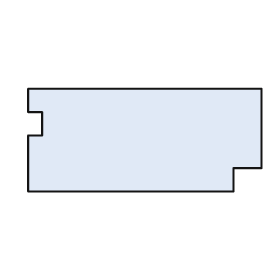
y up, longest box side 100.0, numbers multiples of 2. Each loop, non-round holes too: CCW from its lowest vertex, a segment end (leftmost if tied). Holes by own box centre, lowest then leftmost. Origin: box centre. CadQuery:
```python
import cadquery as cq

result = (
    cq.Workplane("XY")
    .moveTo(-50.0, -22.0)
    .lineTo(38.0, -22.0)
    .lineTo(38.0, -12.0)
    .lineTo(50.0, -12.0)
    .lineTo(50.0, 22.0)
    .lineTo(-50.0, 22.0)
    .lineTo(-50.0, 12.0)
    .lineTo(-44.0, 12.0)
    .lineTo(-44.0, 2.0)
    .lineTo(-50.0, 2.0)
    .close()
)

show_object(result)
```